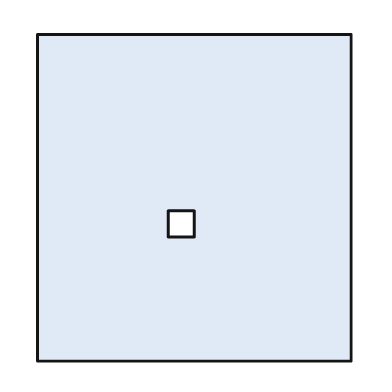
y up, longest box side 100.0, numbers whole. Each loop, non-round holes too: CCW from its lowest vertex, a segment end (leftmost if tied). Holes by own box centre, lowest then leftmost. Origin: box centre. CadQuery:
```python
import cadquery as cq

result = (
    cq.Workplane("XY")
    .moveTo(-48.0, -50.0)
    .lineTo(48.0, -50.0)
    .lineTo(48.0, 50.0)
    .lineTo(-48.0, 50.0)
    .close()
    .moveTo(-8.0, -12.0)
    .lineTo(0.0, -12.0)
    .lineTo(0.0, -4.0)
    .lineTo(-8.0, -4.0)
    .close()
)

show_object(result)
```